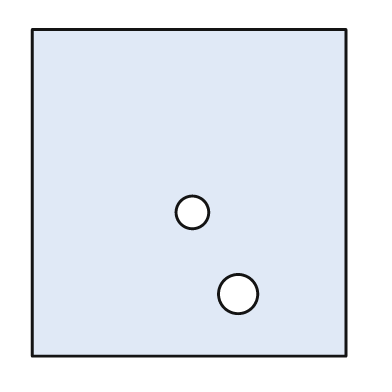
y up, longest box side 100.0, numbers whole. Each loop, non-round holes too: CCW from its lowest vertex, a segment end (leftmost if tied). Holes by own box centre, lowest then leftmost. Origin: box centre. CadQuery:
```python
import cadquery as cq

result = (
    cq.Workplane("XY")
    .moveTo(-48.0, -50.0)
    .lineTo(48.0, -50.0)
    .lineTo(48.0, 50.0)
    .lineTo(-48.0, 50.0)
    .close()
    .moveTo(15.0, -31.0)
    .circle(6.0)
    .moveTo(1.0, -6.0)
    .circle(5.0)
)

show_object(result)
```